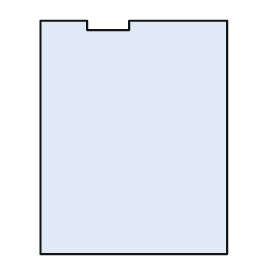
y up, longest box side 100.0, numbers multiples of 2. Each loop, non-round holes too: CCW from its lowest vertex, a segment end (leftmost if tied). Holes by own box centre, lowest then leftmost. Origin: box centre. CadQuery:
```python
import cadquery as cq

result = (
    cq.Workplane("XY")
    .moveTo(-40.0, -50.0)
    .lineTo(40.0, -50.0)
    .lineTo(40.0, 50.0)
    .lineTo(-2.0, 50.0)
    .lineTo(-2.0, 46.0)
    .lineTo(-20.0, 46.0)
    .lineTo(-20.0, 50.0)
    .lineTo(-40.0, 50.0)
    .close()
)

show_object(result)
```